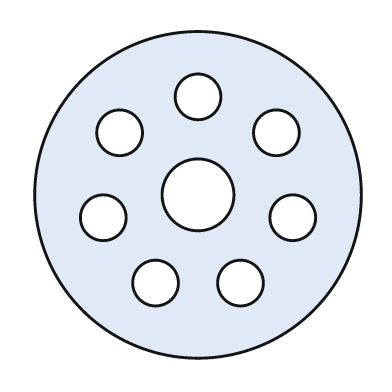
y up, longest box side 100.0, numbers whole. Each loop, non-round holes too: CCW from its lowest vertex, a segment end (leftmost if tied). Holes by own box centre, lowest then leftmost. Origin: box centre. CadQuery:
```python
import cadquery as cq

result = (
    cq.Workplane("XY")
    .moveTo(0.0, 0.0)
    .circle(50.0)
    .moveTo(-13.0, -27.0)
    .circle(7.0)
    .moveTo(13.0, -27.0)
    .circle(7.0)
    .moveTo(-29.0, -7.0)
    .circle(7.0)
    .moveTo(29.0, -7.0)
    .circle(7.0)
    .moveTo(0.0, 0.0)
    .circle(11.0)
    .moveTo(-24.0, 19.0)
    .circle(7.0)
    .moveTo(24.0, 19.0)
    .circle(7.0)
    .moveTo(0.0, 30.0)
    .circle(7.0)
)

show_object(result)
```